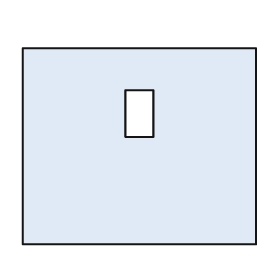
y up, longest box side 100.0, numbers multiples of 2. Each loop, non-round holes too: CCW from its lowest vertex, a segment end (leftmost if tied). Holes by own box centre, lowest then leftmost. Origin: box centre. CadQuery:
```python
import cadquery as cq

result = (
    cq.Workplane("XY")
    .moveTo(-50.0, -42.0)
    .lineTo(50.0, -42.0)
    .lineTo(50.0, 42.0)
    .lineTo(-50.0, 42.0)
    .close()
    .moveTo(-6.0, 4.0)
    .lineTo(6.0, 4.0)
    .lineTo(6.0, 24.0)
    .lineTo(-6.0, 24.0)
    .close()
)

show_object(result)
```